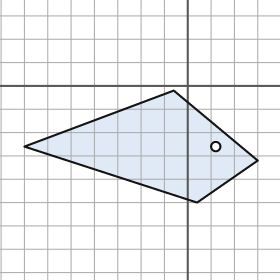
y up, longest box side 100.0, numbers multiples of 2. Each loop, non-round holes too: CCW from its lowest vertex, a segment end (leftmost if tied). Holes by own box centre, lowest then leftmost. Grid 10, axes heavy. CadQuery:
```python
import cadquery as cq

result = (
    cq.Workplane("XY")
    .moveTo(4.0, -50.0)
    .lineTo(30.0, -32.0)
    .lineTo(-6.0, -2.0)
    .lineTo(-70.0, -26.0)
    .close()
    .moveTo(12.0, -26.0)
    .circle(2.0)
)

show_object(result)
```